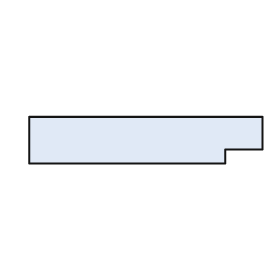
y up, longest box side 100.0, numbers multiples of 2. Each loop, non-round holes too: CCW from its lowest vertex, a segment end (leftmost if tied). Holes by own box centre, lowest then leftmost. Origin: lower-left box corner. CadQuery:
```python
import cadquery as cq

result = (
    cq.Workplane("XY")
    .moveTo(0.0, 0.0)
    .lineTo(84.0, 0.0)
    .lineTo(84.0, 6.0)
    .lineTo(100.0, 6.0)
    .lineTo(100.0, 20.0)
    .lineTo(0.0, 20.0)
    .close()
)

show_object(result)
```